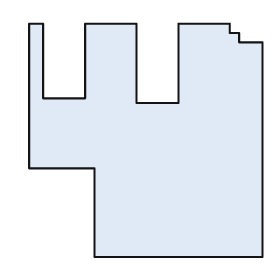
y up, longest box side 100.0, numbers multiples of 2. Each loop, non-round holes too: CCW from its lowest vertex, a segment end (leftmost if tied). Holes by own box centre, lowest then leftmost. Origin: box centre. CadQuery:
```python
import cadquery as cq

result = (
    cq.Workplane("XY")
    .moveTo(-22.0, -50.0)
    .lineTo(50.0, -50.0)
    .lineTo(50.0, 42.0)
    .lineTo(40.0, 42.0)
    .lineTo(40.0, 46.0)
    .lineTo(36.0, 46.0)
    .lineTo(36.0, 50.0)
    .lineTo(14.0, 50.0)
    .lineTo(14.0, 16.0)
    .lineTo(-4.0, 16.0)
    .lineTo(-4.0, 50.0)
    .lineTo(-26.0, 50.0)
    .lineTo(-26.0, 18.0)
    .lineTo(-44.0, 18.0)
    .lineTo(-44.0, 50.0)
    .lineTo(-50.0, 50.0)
    .lineTo(-50.0, -12.0)
    .lineTo(-22.0, -12.0)
    .close()
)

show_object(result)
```